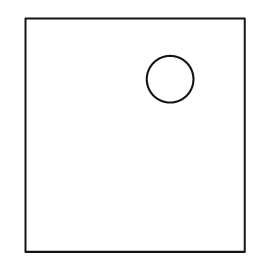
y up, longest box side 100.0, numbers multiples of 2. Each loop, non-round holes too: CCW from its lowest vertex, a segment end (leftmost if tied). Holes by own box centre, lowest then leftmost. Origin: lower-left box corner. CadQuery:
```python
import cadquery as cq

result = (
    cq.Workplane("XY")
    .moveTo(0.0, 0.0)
    .lineTo(94.0, 0.0)
    .lineTo(94.0, 100.0)
    .lineTo(0.0, 100.0)
    .close()
    .moveTo(62.0, 74.0)
    .circle(10.0)
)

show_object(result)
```